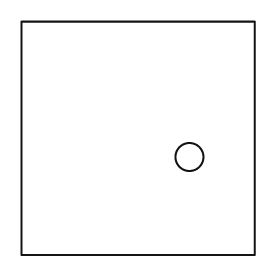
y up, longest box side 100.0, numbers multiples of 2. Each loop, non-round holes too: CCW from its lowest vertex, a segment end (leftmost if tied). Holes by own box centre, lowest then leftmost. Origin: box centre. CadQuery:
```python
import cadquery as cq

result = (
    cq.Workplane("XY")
    .moveTo(-50.0, -50.0)
    .lineTo(50.0, -50.0)
    .lineTo(50.0, 50.0)
    .lineTo(-50.0, 50.0)
    .close()
    .moveTo(22.0, -8.0)
    .circle(6.0)
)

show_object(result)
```